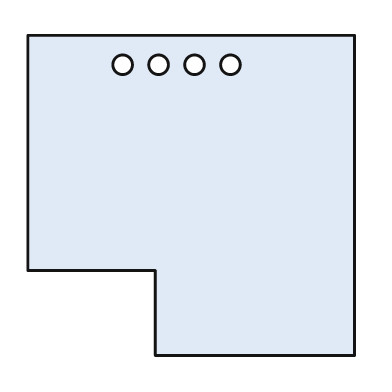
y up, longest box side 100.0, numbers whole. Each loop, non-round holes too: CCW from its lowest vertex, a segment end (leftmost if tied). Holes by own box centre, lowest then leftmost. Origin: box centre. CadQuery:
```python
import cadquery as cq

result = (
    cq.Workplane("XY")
    .moveTo(-11.0, -49.0)
    .lineTo(50.0, -49.0)
    .lineTo(50.0, 49.0)
    .lineTo(-50.0, 49.0)
    .lineTo(-50.0, -23.0)
    .lineTo(-11.0, -23.0)
    .close()
    .moveTo(-21.0, 40.0)
    .circle(3.0)
    .moveTo(-10.0, 40.0)
    .circle(3.0)
    .moveTo(1.0, 40.0)
    .circle(3.0)
    .moveTo(12.0, 40.0)
    .circle(3.0)
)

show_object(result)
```